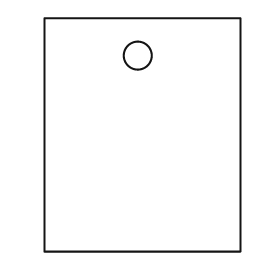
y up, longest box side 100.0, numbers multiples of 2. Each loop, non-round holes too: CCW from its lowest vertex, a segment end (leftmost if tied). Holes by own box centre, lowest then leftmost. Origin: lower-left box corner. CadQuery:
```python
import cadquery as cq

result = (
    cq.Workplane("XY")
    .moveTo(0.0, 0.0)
    .lineTo(84.0, 0.0)
    .lineTo(84.0, 100.0)
    .lineTo(0.0, 100.0)
    .close()
    .moveTo(40.0, 84.0)
    .circle(6.0)
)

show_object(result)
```